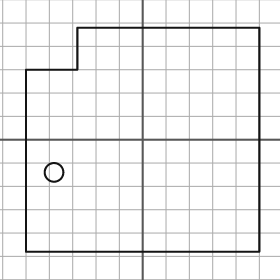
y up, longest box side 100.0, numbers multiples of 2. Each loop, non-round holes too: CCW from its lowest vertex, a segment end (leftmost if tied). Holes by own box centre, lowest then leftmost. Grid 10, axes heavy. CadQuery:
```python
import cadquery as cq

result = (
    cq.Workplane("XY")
    .moveTo(-50.0, -48.0)
    .lineTo(50.0, -48.0)
    .lineTo(50.0, 48.0)
    .lineTo(-28.0, 48.0)
    .lineTo(-28.0, 30.0)
    .lineTo(-50.0, 30.0)
    .close()
    .moveTo(-38.0, -14.0)
    .circle(4.0)
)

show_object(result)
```